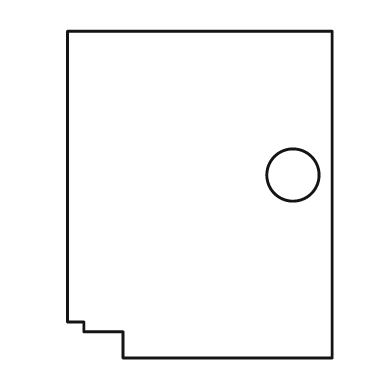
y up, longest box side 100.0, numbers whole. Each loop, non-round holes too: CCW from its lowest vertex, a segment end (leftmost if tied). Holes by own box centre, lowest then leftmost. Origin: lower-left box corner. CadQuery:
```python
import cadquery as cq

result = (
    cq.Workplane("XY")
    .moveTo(17.0, 0.0)
    .lineTo(81.0, 0.0)
    .lineTo(81.0, 100.0)
    .lineTo(0.0, 100.0)
    .lineTo(0.0, 11.0)
    .lineTo(5.0, 11.0)
    .lineTo(5.0, 8.0)
    .lineTo(17.0, 8.0)
    .close()
    .moveTo(69.0, 56.0)
    .circle(8.0)
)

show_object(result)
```